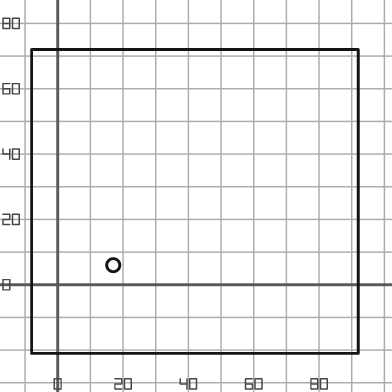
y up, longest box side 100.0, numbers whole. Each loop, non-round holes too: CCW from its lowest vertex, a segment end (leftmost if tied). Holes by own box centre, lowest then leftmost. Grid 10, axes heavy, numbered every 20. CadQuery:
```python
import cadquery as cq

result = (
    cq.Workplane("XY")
    .moveTo(-8.0, -21.0)
    .lineTo(92.0, -21.0)
    .lineTo(92.0, 72.0)
    .lineTo(-8.0, 72.0)
    .close()
    .moveTo(17.0, 6.0)
    .circle(2.0)
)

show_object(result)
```